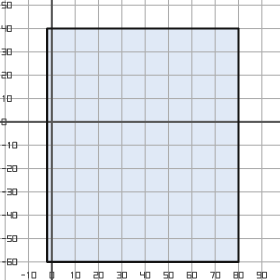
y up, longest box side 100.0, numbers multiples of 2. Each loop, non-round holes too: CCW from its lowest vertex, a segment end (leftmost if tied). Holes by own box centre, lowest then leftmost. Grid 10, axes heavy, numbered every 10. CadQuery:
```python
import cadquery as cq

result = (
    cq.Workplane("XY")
    .moveTo(-2.0, -60.0)
    .lineTo(80.0, -60.0)
    .lineTo(80.0, 40.0)
    .lineTo(-2.0, 40.0)
    .close()
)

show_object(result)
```